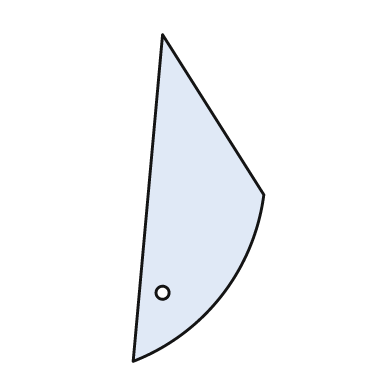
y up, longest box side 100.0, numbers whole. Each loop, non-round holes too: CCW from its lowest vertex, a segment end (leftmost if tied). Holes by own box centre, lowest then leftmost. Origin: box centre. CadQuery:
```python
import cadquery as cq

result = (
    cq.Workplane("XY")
    .moveTo(-20.0, -50.0)
    .threePointArc((7.0, -30.0), (20.0, 1.0))
    .lineTo(-11.0, 50.0)
    .close()
    .moveTo(-11.0, -29.0)
    .circle(2.0)
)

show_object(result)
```